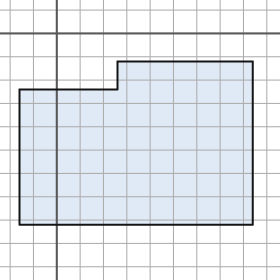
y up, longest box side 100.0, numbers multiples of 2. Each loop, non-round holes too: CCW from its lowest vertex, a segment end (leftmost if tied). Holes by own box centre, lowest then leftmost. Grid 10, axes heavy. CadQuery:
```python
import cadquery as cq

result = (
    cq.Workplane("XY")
    .moveTo(-16.0, -82.0)
    .lineTo(84.0, -82.0)
    .lineTo(84.0, -12.0)
    .lineTo(26.0, -12.0)
    .lineTo(26.0, -24.0)
    .lineTo(-16.0, -24.0)
    .close()
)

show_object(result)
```